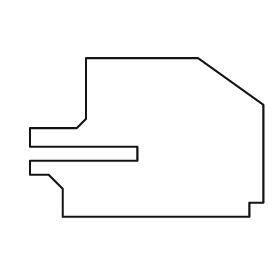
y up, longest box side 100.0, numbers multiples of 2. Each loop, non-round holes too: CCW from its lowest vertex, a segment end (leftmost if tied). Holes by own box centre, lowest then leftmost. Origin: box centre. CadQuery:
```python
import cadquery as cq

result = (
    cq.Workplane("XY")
    .moveTo(-36.0, -34.0)
    .lineTo(44.0, -34.0)
    .lineTo(44.0, -28.0)
    .lineTo(50.0, -28.0)
    .lineTo(50.0, 14.0)
    .lineTo(22.0, 34.0)
    .lineTo(-26.0, 34.0)
    .lineTo(-26.0, 8.0)
    .lineTo(-30.0, 4.0)
    .lineTo(-50.0, 4.0)
    .lineTo(-50.0, -4.0)
    .lineTo(-4.0, -4.0)
    .lineTo(-4.0, -10.0)
    .lineTo(-50.0, -10.0)
    .lineTo(-50.0, -16.0)
    .lineTo(-42.0, -16.0)
    .lineTo(-36.0, -22.0)
    .close()
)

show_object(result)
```